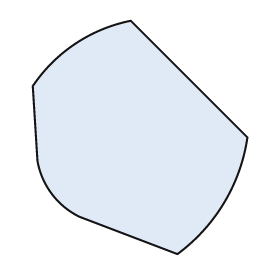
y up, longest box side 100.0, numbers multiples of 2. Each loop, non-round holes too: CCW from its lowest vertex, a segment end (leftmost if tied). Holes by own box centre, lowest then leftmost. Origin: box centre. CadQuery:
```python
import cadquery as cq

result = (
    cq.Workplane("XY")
    .moveTo(16.0, -50.0)
    .threePointArc((36.0, -28.0), (46.0, 0.0))
    .lineTo(-4.0, 50.0)
    .threePointArc((-28.0, 40.0), (-46.0, 22.0))
    .lineTo(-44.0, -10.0)
    .threePointArc((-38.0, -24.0), (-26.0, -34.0))
    .close()
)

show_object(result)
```